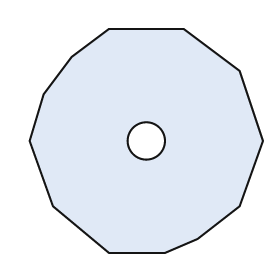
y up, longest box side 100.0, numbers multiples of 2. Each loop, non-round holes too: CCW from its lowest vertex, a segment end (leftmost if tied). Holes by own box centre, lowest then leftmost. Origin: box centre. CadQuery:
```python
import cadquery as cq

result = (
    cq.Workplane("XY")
    .moveTo(-16.0, -48.0)
    .lineTo(8.0, -48.0)
    .lineTo(22.0, -42.0)
    .lineTo(40.0, -28.0)
    .lineTo(50.0, 0.0)
    .lineTo(40.0, 30.0)
    .lineTo(16.0, 48.0)
    .lineTo(-16.0, 48.0)
    .lineTo(-32.0, 36.0)
    .lineTo(-44.0, 20.0)
    .lineTo(-50.0, 0.0)
    .lineTo(-40.0, -28.0)
    .close()
    .moveTo(0.0, 0.0)
    .circle(8.0)
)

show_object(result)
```